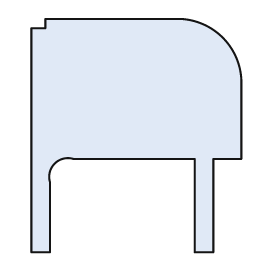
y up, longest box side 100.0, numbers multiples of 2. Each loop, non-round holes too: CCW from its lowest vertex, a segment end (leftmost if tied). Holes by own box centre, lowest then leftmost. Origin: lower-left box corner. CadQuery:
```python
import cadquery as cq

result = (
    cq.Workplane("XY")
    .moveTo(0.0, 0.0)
    .lineTo(8.0, 0.0)
    .lineTo(8.0, 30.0)
    .threePointArc((10.0, 38.0), (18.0, 40.0))
    .lineTo(70.0, 40.0)
    .lineTo(70.0, 0.0)
    .lineTo(78.0, 0.0)
    .lineTo(78.0, 40.0)
    .lineTo(90.0, 40.0)
    .lineTo(90.0, 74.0)
    .threePointArc((82.0, 92.0), (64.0, 100.0))
    .lineTo(6.0, 100.0)
    .lineTo(6.0, 96.0)
    .lineTo(0.0, 96.0)
    .close()
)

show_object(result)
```